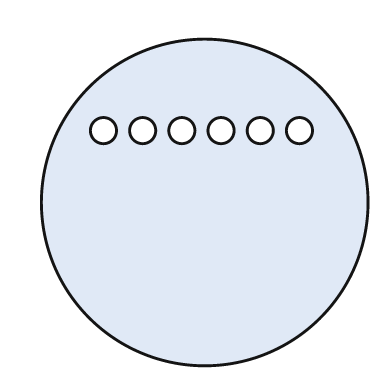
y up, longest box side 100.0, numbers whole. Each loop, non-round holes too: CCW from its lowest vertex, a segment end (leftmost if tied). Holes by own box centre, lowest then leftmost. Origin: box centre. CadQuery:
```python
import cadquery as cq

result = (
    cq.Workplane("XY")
    .moveTo(0.0, 0.0)
    .circle(50.0)
    .moveTo(-31.0, 22.0)
    .circle(4.0)
    .moveTo(-19.0, 22.0)
    .circle(4.0)
    .moveTo(-7.0, 22.0)
    .circle(4.0)
    .moveTo(5.0, 22.0)
    .circle(4.0)
    .moveTo(17.0, 22.0)
    .circle(4.0)
    .moveTo(29.0, 22.0)
    .circle(4.0)
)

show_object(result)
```